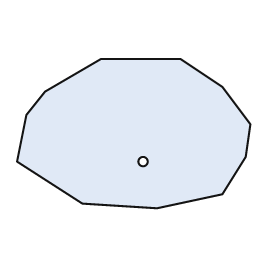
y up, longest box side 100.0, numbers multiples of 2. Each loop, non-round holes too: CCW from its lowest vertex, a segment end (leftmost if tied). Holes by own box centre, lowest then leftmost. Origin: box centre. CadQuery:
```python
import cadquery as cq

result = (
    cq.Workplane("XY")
    .moveTo(10.0, -32.0)
    .lineTo(38.0, -26.0)
    .lineTo(48.0, -10.0)
    .lineTo(50.0, 4.0)
    .lineTo(38.0, 20.0)
    .lineTo(20.0, 32.0)
    .lineTo(-14.0, 32.0)
    .lineTo(-38.0, 18.0)
    .lineTo(-46.0, 8.0)
    .lineTo(-50.0, -12.0)
    .lineTo(-22.0, -30.0)
    .close()
    .moveTo(4.0, -12.0)
    .circle(2.0)
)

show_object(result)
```